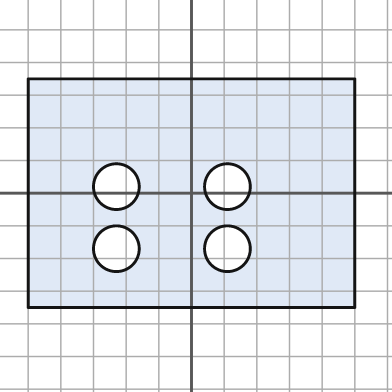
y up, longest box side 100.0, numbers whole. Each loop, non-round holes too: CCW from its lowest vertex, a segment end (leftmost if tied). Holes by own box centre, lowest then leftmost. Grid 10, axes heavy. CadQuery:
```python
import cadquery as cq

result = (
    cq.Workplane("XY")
    .moveTo(-50.0, -35.0)
    .lineTo(50.0, -35.0)
    .lineTo(50.0, 35.0)
    .lineTo(-50.0, 35.0)
    .close()
    .moveTo(-23.0, -17.0)
    .circle(7.0)
    .moveTo(11.0, -17.0)
    .circle(7.0)
    .moveTo(-23.0, 2.0)
    .circle(7.0)
    .moveTo(11.0, 2.0)
    .circle(7.0)
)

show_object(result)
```